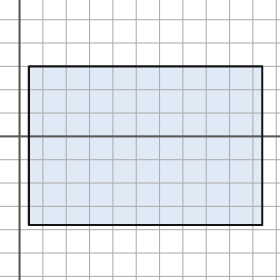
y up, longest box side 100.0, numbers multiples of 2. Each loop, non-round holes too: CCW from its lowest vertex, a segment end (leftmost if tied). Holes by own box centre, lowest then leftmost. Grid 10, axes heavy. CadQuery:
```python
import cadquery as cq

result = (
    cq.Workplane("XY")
    .moveTo(4.0, -38.0)
    .lineTo(104.0, -38.0)
    .lineTo(104.0, 30.0)
    .lineTo(4.0, 30.0)
    .close()
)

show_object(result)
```